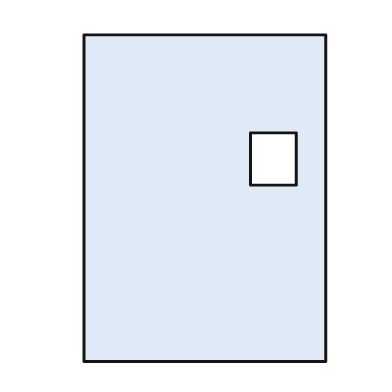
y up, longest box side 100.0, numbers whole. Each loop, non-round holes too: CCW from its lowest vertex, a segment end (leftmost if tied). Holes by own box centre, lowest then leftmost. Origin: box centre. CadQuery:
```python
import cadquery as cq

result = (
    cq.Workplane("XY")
    .moveTo(-37.0, -50.0)
    .lineTo(37.0, -50.0)
    .lineTo(37.0, 50.0)
    .lineTo(-37.0, 50.0)
    .close()
    .moveTo(14.0, 4.0)
    .lineTo(28.0, 4.0)
    .lineTo(28.0, 20.0)
    .lineTo(14.0, 20.0)
    .close()
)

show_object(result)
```